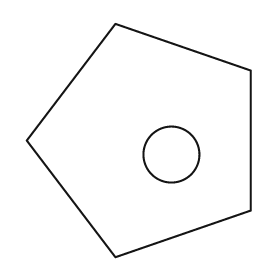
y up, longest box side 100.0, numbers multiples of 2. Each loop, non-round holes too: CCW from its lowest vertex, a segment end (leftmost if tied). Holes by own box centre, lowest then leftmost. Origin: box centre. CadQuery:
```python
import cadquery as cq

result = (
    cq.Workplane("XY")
    .moveTo(-10.0, -50.0)
    .lineTo(48.0, -30.0)
    .lineTo(48.0, 30.0)
    .lineTo(-10.0, 50.0)
    .lineTo(-48.0, 0.0)
    .close()
    .moveTo(14.0, -6.0)
    .circle(12.0)
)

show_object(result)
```